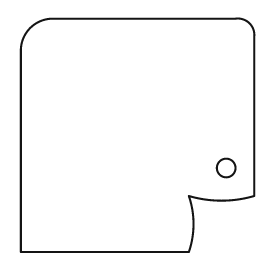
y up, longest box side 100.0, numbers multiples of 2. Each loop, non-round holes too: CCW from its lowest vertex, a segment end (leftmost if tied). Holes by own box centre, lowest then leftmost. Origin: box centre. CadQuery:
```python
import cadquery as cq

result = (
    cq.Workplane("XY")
    .moveTo(-50.0, -50.0)
    .lineTo(22.0, -50.0)
    .threePointArc((24.0, -38.0), (22.0, -26.0))
    .threePointArc((36.0, -28.0), (50.0, -26.0))
    .lineTo(50.0, 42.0)
    .threePointArc((48.0, 48.0), (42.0, 50.0))
    .lineTo(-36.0, 50.0)
    .threePointArc((-46.0, 46.0), (-50.0, 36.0))
    .close()
    .moveTo(38.0, -14.0)
    .circle(4.0)
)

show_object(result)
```